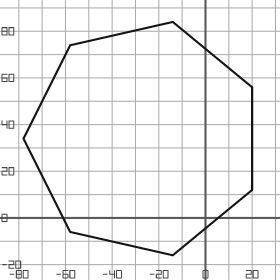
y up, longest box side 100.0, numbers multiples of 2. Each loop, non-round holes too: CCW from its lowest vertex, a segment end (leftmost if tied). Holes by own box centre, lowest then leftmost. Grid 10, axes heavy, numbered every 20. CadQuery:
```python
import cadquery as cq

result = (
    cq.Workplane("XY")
    .moveTo(-14.0, -16.0)
    .lineTo(20.0, 12.0)
    .lineTo(20.0, 56.0)
    .lineTo(-14.0, 84.0)
    .lineTo(-58.0, 74.0)
    .lineTo(-78.0, 34.0)
    .lineTo(-58.0, -6.0)
    .close()
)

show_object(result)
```